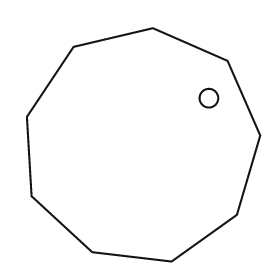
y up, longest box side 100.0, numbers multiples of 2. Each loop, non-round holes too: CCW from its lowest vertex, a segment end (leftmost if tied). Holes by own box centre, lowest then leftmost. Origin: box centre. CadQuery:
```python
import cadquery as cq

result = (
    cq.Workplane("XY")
    .moveTo(12.0, -50.0)
    .lineTo(40.0, -30.0)
    .lineTo(50.0, 4.0)
    .lineTo(36.0, 36.0)
    .lineTo(4.0, 50.0)
    .lineTo(-30.0, 42.0)
    .lineTo(-50.0, 12.0)
    .lineTo(-48.0, -22.0)
    .lineTo(-22.0, -46.0)
    .close()
    .moveTo(28.0, 20.0)
    .circle(4.0)
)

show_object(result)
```